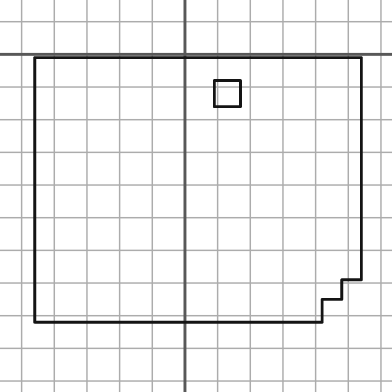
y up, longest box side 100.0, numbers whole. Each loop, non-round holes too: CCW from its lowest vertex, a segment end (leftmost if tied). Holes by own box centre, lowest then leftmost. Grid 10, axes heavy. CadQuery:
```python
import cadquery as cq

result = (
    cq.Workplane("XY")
    .moveTo(-46.0, -82.0)
    .lineTo(42.0, -82.0)
    .lineTo(42.0, -75.0)
    .lineTo(48.0, -75.0)
    .lineTo(48.0, -69.0)
    .lineTo(54.0, -69.0)
    .lineTo(54.0, -1.0)
    .lineTo(-46.0, -1.0)
    .close()
    .moveTo(9.0, -16.0)
    .lineTo(17.0, -16.0)
    .lineTo(17.0, -8.0)
    .lineTo(9.0, -8.0)
    .close()
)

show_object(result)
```